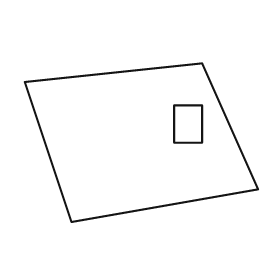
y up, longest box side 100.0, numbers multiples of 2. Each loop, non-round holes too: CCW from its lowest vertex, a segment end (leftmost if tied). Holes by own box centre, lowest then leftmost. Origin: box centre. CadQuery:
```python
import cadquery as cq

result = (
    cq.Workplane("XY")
    .moveTo(-30.0, -34.0)
    .lineTo(50.0, -20.0)
    .lineTo(26.0, 34.0)
    .lineTo(-50.0, 26.0)
    .close()
    .moveTo(14.0, 0.0)
    .lineTo(26.0, 0.0)
    .lineTo(26.0, 16.0)
    .lineTo(14.0, 16.0)
    .close()
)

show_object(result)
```